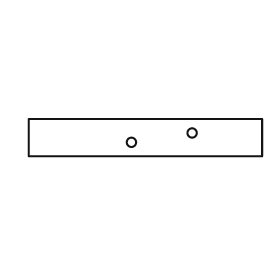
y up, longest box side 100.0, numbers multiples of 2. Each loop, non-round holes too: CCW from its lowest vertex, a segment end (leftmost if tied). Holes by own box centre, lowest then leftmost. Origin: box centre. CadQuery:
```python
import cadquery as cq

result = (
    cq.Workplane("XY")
    .moveTo(-50.0, -8.0)
    .lineTo(50.0, -8.0)
    .lineTo(50.0, 8.0)
    .lineTo(-50.0, 8.0)
    .close()
    .moveTo(-6.0, -2.0)
    .circle(2.0)
    .moveTo(20.0, 2.0)
    .circle(2.0)
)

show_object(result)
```